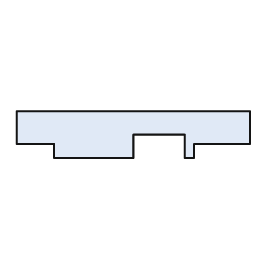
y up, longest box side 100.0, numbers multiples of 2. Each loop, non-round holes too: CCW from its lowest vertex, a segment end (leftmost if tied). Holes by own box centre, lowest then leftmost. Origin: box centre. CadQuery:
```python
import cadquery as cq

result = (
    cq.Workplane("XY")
    .moveTo(-34.0, -10.0)
    .lineTo(0.0, -10.0)
    .lineTo(0.0, 0.0)
    .lineTo(22.0, 0.0)
    .lineTo(22.0, -10.0)
    .lineTo(26.0, -10.0)
    .lineTo(26.0, -4.0)
    .lineTo(50.0, -4.0)
    .lineTo(50.0, 10.0)
    .lineTo(-50.0, 10.0)
    .lineTo(-50.0, -4.0)
    .lineTo(-34.0, -4.0)
    .close()
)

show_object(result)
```